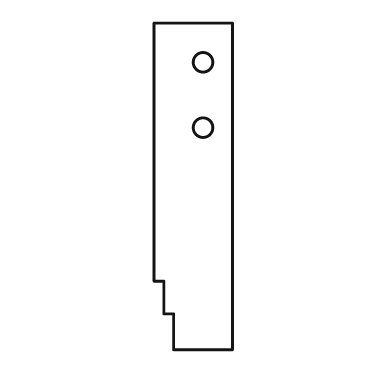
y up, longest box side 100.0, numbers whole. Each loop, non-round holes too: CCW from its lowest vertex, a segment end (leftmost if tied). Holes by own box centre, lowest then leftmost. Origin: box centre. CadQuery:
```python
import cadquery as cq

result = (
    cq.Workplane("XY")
    .moveTo(-6.0, -50.0)
    .lineTo(12.0, -50.0)
    .lineTo(12.0, 50.0)
    .lineTo(-12.0, 50.0)
    .lineTo(-12.0, -29.0)
    .lineTo(-9.0, -29.0)
    .lineTo(-9.0, -39.0)
    .lineTo(-6.0, -39.0)
    .close()
    .moveTo(3.0, 18.0)
    .circle(3.0)
    .moveTo(3.0, 38.0)
    .circle(3.0)
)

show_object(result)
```